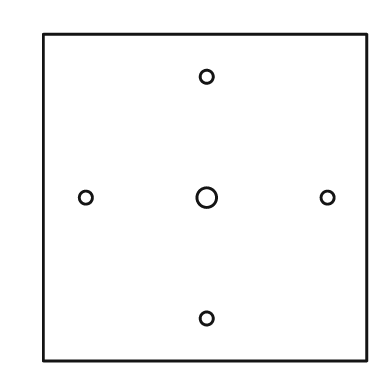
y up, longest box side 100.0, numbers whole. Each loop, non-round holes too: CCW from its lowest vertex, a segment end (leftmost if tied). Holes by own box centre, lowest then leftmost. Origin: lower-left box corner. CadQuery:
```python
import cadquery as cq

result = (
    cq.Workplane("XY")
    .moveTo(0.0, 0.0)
    .lineTo(99.0, 0.0)
    .lineTo(99.0, 100.0)
    .lineTo(0.0, 100.0)
    .close()
    .moveTo(50.0, 13.0)
    .circle(2.0)
    .moveTo(13.0, 50.0)
    .circle(2.0)
    .moveTo(50.0, 50.0)
    .circle(3.0)
    .moveTo(87.0, 50.0)
    .circle(2.0)
    .moveTo(50.0, 87.0)
    .circle(2.0)
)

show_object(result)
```